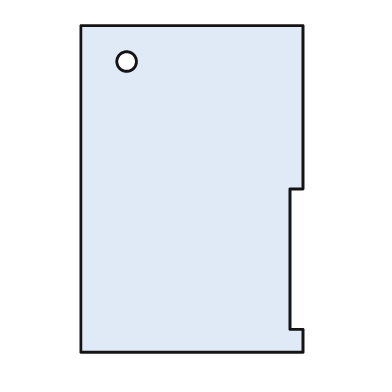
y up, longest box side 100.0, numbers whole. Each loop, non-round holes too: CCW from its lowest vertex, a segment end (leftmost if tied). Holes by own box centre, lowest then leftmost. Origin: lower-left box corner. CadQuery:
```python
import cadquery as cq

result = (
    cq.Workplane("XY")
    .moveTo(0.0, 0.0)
    .lineTo(68.0, 0.0)
    .lineTo(68.0, 7.0)
    .lineTo(64.0, 7.0)
    .lineTo(64.0, 50.0)
    .lineTo(68.0, 50.0)
    .lineTo(68.0, 100.0)
    .lineTo(0.0, 100.0)
    .close()
    .moveTo(14.0, 89.0)
    .circle(3.0)
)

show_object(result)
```